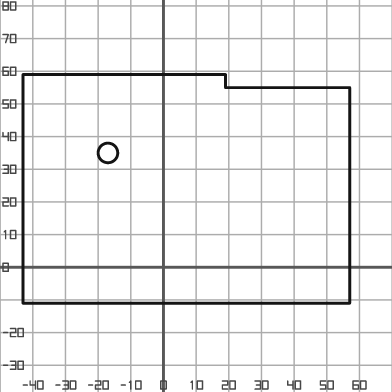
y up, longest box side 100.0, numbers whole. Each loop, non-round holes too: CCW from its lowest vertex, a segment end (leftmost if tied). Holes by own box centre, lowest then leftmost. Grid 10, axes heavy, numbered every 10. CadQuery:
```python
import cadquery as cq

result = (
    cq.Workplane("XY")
    .moveTo(-43.0, -11.0)
    .lineTo(57.0, -11.0)
    .lineTo(57.0, 55.0)
    .lineTo(19.0, 55.0)
    .lineTo(19.0, 59.0)
    .lineTo(-43.0, 59.0)
    .close()
    .moveTo(-17.0, 35.0)
    .circle(3.0)
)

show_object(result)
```